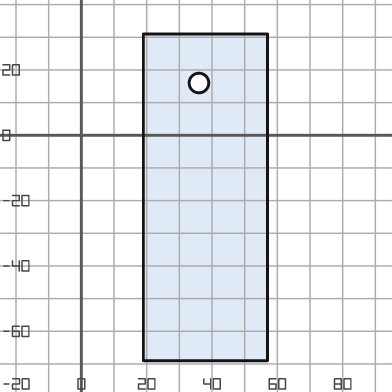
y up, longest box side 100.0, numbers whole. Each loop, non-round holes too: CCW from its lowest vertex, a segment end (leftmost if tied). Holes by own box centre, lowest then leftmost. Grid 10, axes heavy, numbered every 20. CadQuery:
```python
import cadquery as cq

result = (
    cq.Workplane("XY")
    .moveTo(19.0, -69.0)
    .lineTo(57.0, -69.0)
    .lineTo(57.0, 31.0)
    .lineTo(19.0, 31.0)
    .close()
    .moveTo(36.0, 16.0)
    .circle(3.0)
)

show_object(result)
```